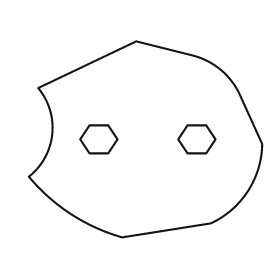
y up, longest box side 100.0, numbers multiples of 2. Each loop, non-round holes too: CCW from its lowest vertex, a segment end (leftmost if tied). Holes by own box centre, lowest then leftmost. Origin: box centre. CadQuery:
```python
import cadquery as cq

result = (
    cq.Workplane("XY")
    .moveTo(-10.0, -42.0)
    .lineTo(28.0, -36.0)
    .threePointArc((44.0, -22.0), (50.0, -2.0))
    .lineTo(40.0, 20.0)
    .threePointArc((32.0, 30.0), (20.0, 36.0))
    .lineTo(-4.0, 42.0)
    .lineTo(-46.0, 22.0)
    .threePointArc((-40.0, 2.0), (-50.0, -16.0))
    .threePointArc((-32.0, -32.0), (-10.0, -42.0))
    .close()
    .moveTo(-24.0, -6.0)
    .lineTo(-16.0, -6.0)
    .lineTo(-12.0, 0.0)
    .lineTo(-16.0, 6.0)
    .lineTo(-24.0, 6.0)
    .lineTo(-28.0, 0.0)
    .close()
    .moveTo(18.0, -6.0)
    .lineTo(26.0, -6.0)
    .lineTo(30.0, 0.0)
    .lineTo(26.0, 6.0)
    .lineTo(18.0, 6.0)
    .lineTo(14.0, 0.0)
    .close()
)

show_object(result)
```